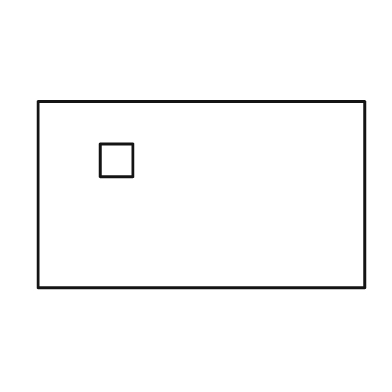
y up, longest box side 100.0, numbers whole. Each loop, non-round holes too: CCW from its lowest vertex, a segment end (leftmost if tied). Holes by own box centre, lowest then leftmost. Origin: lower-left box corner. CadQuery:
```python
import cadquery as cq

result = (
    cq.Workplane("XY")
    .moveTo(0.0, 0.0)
    .lineTo(100.0, 0.0)
    .lineTo(100.0, 57.0)
    .lineTo(0.0, 57.0)
    .close()
    .moveTo(19.0, 34.0)
    .lineTo(29.0, 34.0)
    .lineTo(29.0, 44.0)
    .lineTo(19.0, 44.0)
    .close()
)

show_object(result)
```